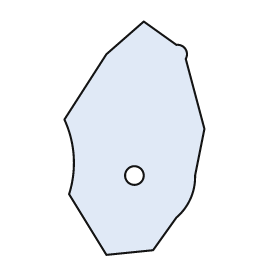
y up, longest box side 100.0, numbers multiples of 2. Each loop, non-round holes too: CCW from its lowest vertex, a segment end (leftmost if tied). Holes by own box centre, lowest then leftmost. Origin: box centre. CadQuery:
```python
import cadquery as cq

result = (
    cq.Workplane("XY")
    .moveTo(-12.0, -50.0)
    .lineTo(8.0, -48.0)
    .lineTo(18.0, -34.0)
    .threePointArc((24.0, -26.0), (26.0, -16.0))
    .lineTo(30.0, 4.0)
    .lineTo(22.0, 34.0)
    .threePointArc((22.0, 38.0), (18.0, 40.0))
    .lineTo(4.0, 50.0)
    .lineTo(-12.0, 36.0)
    .lineTo(-30.0, 8.0)
    .threePointArc((-26.0, -8.0), (-28.0, -24.0))
    .close()
    .moveTo(0.0, -16.0)
    .circle(4.0)
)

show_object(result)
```